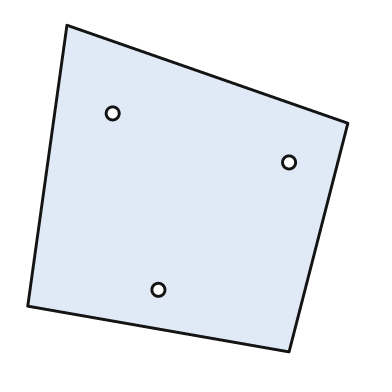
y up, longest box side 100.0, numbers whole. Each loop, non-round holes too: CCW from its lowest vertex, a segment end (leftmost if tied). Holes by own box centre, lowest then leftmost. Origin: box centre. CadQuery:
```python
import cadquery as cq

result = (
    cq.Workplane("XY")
    .moveTo(31.0, -50.0)
    .lineTo(49.0, 20.0)
    .lineTo(-37.0, 50.0)
    .lineTo(-49.0, -36.0)
    .close()
    .moveTo(-9.0, -31.0)
    .circle(2.0)
    .moveTo(31.0, 8.0)
    .circle(2.0)
    .moveTo(-23.0, 23.0)
    .circle(2.0)
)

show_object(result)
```